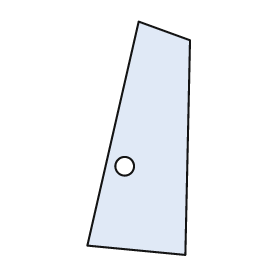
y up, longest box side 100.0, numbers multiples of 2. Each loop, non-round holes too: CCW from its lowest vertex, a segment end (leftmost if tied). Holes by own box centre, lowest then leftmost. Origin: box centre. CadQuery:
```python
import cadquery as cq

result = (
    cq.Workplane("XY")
    .moveTo(20.0, -50.0)
    .lineTo(22.0, 42.0)
    .lineTo(0.0, 50.0)
    .lineTo(-22.0, -46.0)
    .close()
    .moveTo(-6.0, -12.0)
    .circle(4.0)
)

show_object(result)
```